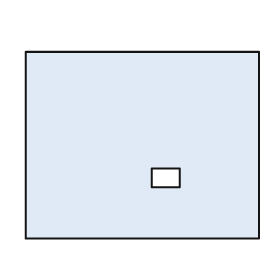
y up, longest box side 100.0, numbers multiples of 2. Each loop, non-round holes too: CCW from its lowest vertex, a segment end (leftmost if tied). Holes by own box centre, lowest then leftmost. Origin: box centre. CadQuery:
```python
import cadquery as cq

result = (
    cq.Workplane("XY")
    .moveTo(-50.0, -40.0)
    .lineTo(50.0, -40.0)
    .lineTo(50.0, 40.0)
    .lineTo(-50.0, 40.0)
    .close()
    .moveTo(4.0, -18.0)
    .lineTo(16.0, -18.0)
    .lineTo(16.0, -10.0)
    .lineTo(4.0, -10.0)
    .close()
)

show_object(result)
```